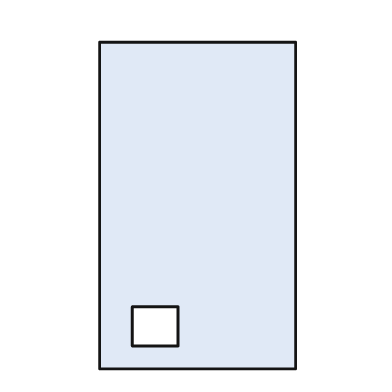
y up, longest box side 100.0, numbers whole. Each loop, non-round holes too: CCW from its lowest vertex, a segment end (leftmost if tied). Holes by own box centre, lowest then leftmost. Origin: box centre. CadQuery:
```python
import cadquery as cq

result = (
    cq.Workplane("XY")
    .moveTo(-30.0, -50.0)
    .lineTo(30.0, -50.0)
    .lineTo(30.0, 50.0)
    .lineTo(-30.0, 50.0)
    .close()
    .moveTo(-20.0, -43.0)
    .lineTo(-6.0, -43.0)
    .lineTo(-6.0, -31.0)
    .lineTo(-20.0, -31.0)
    .close()
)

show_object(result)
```